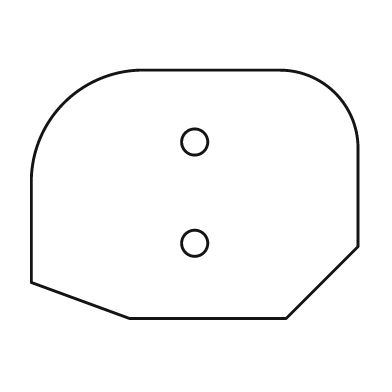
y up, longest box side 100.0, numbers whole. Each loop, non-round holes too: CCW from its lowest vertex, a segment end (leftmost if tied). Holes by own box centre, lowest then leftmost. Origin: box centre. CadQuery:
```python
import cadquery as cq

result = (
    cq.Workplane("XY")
    .moveTo(-20.0, -38.0)
    .lineTo(28.0, -38.0)
    .lineTo(50.0, -16.0)
    .lineTo(50.0, 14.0)
    .threePointArc((43.0, 31.0), (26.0, 38.0))
    .lineTo(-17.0, 38.0)
    .threePointArc((-40.0, 28.0), (-50.0, 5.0))
    .lineTo(-50.0, -27.0)
    .close()
    .moveTo(0.0, -15.0)
    .circle(4.0)
    .moveTo(0.0, 16.0)
    .circle(4.0)
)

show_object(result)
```